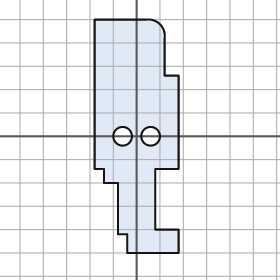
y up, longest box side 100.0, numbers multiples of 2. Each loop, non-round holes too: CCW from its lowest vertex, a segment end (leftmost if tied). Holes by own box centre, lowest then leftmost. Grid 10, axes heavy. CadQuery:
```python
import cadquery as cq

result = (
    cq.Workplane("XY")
    .moveTo(-4.0, -50.0)
    .lineTo(18.0, -50.0)
    .lineTo(18.0, -40.0)
    .lineTo(8.0, -40.0)
    .lineTo(8.0, -14.0)
    .lineTo(18.0, -14.0)
    .lineTo(18.0, 26.0)
    .lineTo(12.0, 26.0)
    .lineTo(12.0, 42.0)
    .threePointArc((10.0, 48.0), (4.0, 50.0))
    .lineTo(-18.0, 50.0)
    .lineTo(-18.0, -14.0)
    .lineTo(-14.0, -14.0)
    .lineTo(-14.0, -20.0)
    .lineTo(-8.0, -20.0)
    .lineTo(-8.0, -42.0)
    .lineTo(-4.0, -42.0)
    .close()
    .moveTo(-6.0, 0.0)
    .circle(4.0)
    .moveTo(6.0, 0.0)
    .circle(4.0)
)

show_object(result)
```